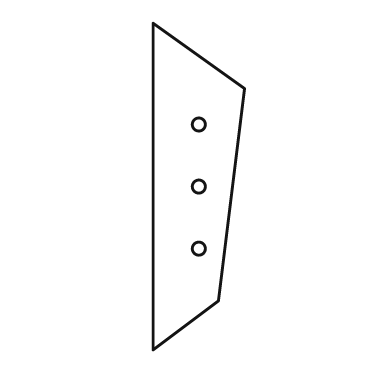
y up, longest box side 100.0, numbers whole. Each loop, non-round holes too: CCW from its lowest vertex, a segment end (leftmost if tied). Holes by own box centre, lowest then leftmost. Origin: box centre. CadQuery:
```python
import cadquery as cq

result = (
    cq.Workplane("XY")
    .moveTo(-14.0, -50.0)
    .lineTo(6.0, -35.0)
    .lineTo(14.0, 30.0)
    .lineTo(-14.0, 50.0)
    .close()
    .moveTo(0.0, -19.0)
    .circle(2.0)
    .moveTo(0.0, 0.0)
    .circle(2.0)
    .moveTo(0.0, 19.0)
    .circle(2.0)
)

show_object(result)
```